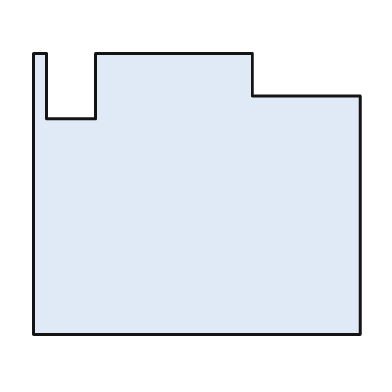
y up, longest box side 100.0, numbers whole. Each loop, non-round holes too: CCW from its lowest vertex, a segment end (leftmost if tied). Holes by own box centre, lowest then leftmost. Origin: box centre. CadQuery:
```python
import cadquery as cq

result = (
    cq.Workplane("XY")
    .moveTo(-50.0, -43.0)
    .lineTo(50.0, -43.0)
    .lineTo(50.0, 30.0)
    .lineTo(17.0, 30.0)
    .lineTo(17.0, 43.0)
    .lineTo(-31.0, 43.0)
    .lineTo(-31.0, 23.0)
    .lineTo(-46.0, 23.0)
    .lineTo(-46.0, 43.0)
    .lineTo(-50.0, 43.0)
    .close()
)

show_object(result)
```